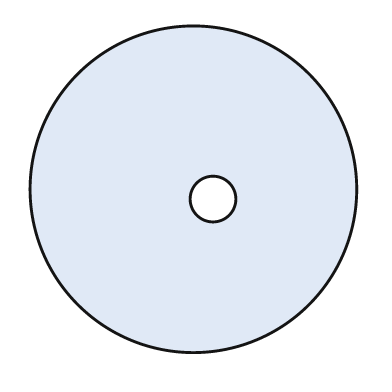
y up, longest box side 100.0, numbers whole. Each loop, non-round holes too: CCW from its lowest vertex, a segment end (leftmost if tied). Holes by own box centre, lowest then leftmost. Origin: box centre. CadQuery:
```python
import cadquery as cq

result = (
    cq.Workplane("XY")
    .moveTo(0.0, 0.0)
    .circle(50.0)
    .moveTo(6.0, -3.0)
    .circle(7.0)
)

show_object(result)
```